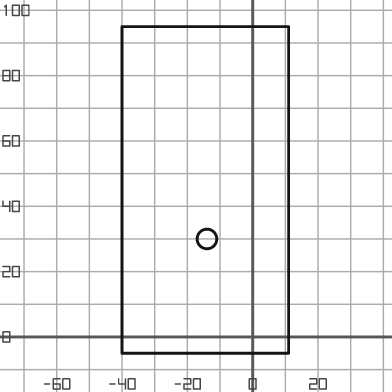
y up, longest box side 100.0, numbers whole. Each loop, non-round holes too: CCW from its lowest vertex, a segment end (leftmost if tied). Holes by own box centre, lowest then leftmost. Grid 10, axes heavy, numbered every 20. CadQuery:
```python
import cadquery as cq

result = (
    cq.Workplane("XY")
    .moveTo(-40.0, -5.0)
    .lineTo(11.0, -5.0)
    .lineTo(11.0, 95.0)
    .lineTo(-40.0, 95.0)
    .close()
    .moveTo(-14.0, 30.0)
    .circle(3.0)
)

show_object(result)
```